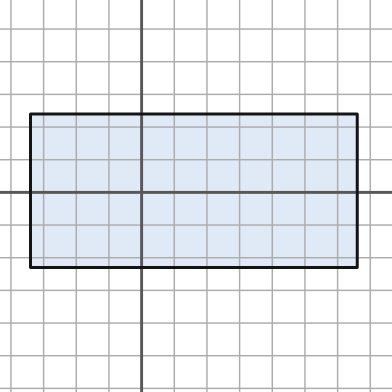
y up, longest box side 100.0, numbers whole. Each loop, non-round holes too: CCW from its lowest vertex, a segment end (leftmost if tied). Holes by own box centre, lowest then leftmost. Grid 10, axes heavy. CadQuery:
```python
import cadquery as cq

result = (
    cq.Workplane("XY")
    .moveTo(-34.0, -23.0)
    .lineTo(66.0, -23.0)
    .lineTo(66.0, 24.0)
    .lineTo(-34.0, 24.0)
    .close()
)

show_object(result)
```